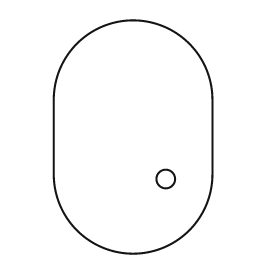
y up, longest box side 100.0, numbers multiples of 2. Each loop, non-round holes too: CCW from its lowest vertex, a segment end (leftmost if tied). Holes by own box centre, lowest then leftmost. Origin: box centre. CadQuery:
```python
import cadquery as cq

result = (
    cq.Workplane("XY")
    .moveTo(-34.0, -16.0)
    .threePointArc((0.0, -50.0), (34.0, -16.0))
    .lineTo(34.0, 16.0)
    .threePointArc((0.0, 50.0), (-34.0, 16.0))
    .close()
    .moveTo(14.0, -18.0)
    .circle(4.0)
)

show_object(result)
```